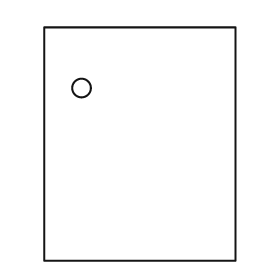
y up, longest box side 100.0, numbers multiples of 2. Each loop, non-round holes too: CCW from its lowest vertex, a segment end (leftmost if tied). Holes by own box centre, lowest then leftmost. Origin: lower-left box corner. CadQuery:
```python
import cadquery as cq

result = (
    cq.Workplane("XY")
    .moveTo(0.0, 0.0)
    .lineTo(82.0, 0.0)
    .lineTo(82.0, 100.0)
    .lineTo(0.0, 100.0)
    .close()
    .moveTo(16.0, 74.0)
    .circle(4.0)
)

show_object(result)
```